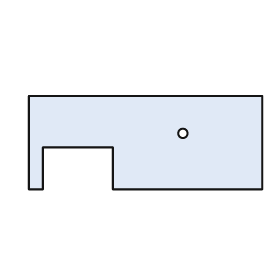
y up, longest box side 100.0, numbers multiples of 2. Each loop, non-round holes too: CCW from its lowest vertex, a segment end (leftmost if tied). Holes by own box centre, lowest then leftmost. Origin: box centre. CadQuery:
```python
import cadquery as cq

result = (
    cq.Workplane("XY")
    .moveTo(-50.0, -20.0)
    .lineTo(-44.0, -20.0)
    .lineTo(-44.0, -2.0)
    .lineTo(-14.0, -2.0)
    .lineTo(-14.0, -20.0)
    .lineTo(50.0, -20.0)
    .lineTo(50.0, 20.0)
    .lineTo(-50.0, 20.0)
    .close()
    .moveTo(16.0, 4.0)
    .circle(2.0)
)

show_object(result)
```